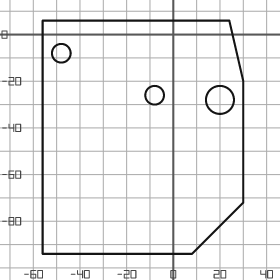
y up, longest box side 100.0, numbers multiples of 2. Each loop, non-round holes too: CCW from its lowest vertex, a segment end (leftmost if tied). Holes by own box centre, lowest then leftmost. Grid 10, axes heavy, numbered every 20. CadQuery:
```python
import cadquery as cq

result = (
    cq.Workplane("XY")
    .moveTo(-56.0, -94.0)
    .lineTo(8.0, -94.0)
    .lineTo(30.0, -72.0)
    .lineTo(30.0, -20.0)
    .lineTo(24.0, 6.0)
    .lineTo(-56.0, 6.0)
    .close()
    .moveTo(20.0, -28.0)
    .circle(6.0)
    .moveTo(-8.0, -26.0)
    .circle(4.0)
    .moveTo(-48.0, -8.0)
    .circle(4.0)
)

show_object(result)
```